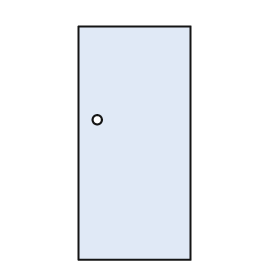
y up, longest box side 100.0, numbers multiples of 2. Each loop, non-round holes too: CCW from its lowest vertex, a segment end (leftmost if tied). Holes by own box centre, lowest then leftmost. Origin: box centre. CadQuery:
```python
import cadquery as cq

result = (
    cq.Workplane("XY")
    .moveTo(-24.0, -50.0)
    .lineTo(24.0, -50.0)
    .lineTo(24.0, 50.0)
    .lineTo(-24.0, 50.0)
    .close()
    .moveTo(-16.0, 10.0)
    .circle(2.0)
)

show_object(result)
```